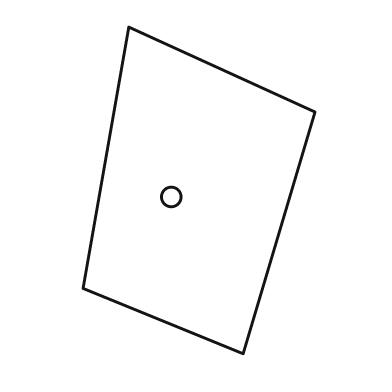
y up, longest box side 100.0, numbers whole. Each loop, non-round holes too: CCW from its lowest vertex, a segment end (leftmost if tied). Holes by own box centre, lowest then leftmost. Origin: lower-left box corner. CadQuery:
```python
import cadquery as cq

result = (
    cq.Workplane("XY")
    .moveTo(49.0, 0.0)
    .lineTo(71.0, 74.0)
    .lineTo(14.0, 100.0)
    .lineTo(0.0, 20.0)
    .close()
    .moveTo(27.0, 48.0)
    .circle(3.0)
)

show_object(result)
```